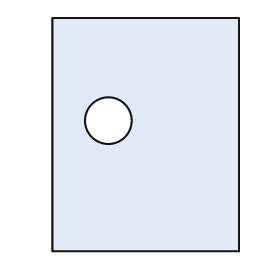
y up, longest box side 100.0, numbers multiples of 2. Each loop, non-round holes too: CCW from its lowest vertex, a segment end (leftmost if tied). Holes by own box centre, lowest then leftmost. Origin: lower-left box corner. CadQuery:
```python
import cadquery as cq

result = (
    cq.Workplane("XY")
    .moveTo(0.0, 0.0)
    .lineTo(80.0, 0.0)
    .lineTo(80.0, 100.0)
    .lineTo(0.0, 100.0)
    .close()
    .moveTo(24.0, 56.0)
    .circle(10.0)
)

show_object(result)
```